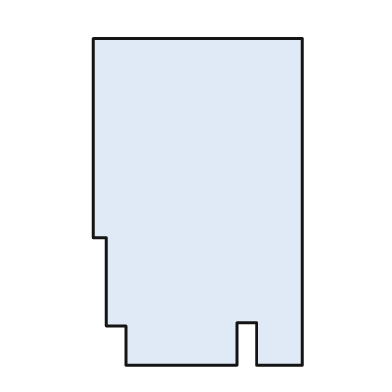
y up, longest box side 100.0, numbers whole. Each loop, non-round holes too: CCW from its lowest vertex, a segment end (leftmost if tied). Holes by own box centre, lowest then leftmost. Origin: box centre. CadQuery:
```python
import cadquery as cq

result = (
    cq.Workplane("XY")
    .moveTo(-22.0, -50.0)
    .lineTo(12.0, -50.0)
    .lineTo(12.0, -37.0)
    .lineTo(18.0, -37.0)
    .lineTo(18.0, -50.0)
    .lineTo(32.0, -50.0)
    .lineTo(32.0, 50.0)
    .lineTo(-32.0, 50.0)
    .lineTo(-32.0, -11.0)
    .lineTo(-28.0, -11.0)
    .lineTo(-28.0, -38.0)
    .lineTo(-22.0, -38.0)
    .close()
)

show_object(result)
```